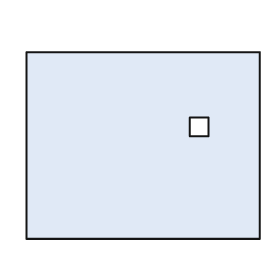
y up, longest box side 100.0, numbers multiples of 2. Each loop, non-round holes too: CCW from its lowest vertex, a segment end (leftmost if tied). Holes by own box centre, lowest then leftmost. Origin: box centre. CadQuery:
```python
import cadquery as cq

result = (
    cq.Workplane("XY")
    .moveTo(-50.0, -40.0)
    .lineTo(50.0, -40.0)
    .lineTo(50.0, 40.0)
    .lineTo(-50.0, 40.0)
    .close()
    .moveTo(20.0, 4.0)
    .lineTo(28.0, 4.0)
    .lineTo(28.0, 12.0)
    .lineTo(20.0, 12.0)
    .close()
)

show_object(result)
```